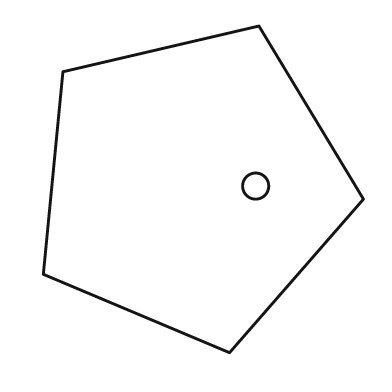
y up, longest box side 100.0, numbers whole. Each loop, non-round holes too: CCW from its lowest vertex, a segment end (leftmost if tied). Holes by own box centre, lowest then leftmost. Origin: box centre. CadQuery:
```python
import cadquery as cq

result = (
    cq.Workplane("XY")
    .moveTo(8.0, -50.0)
    .lineTo(49.0, -3.0)
    .lineTo(17.0, 50.0)
    .lineTo(-43.0, 36.0)
    .lineTo(-49.0, -26.0)
    .close()
    .moveTo(16.0, 1.0)
    .circle(4.0)
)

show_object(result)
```